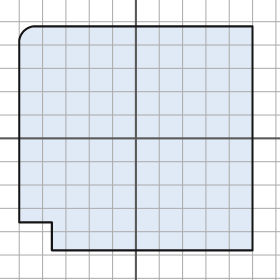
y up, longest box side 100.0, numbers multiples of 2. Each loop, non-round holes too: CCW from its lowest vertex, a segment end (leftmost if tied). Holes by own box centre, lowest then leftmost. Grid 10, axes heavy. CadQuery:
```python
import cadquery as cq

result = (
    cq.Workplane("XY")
    .moveTo(-36.0, -48.0)
    .lineTo(50.0, -48.0)
    .lineTo(50.0, 48.0)
    .lineTo(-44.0, 48.0)
    .threePointArc((-48.0, 46.0), (-50.0, 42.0))
    .lineTo(-50.0, -36.0)
    .lineTo(-36.0, -36.0)
    .close()
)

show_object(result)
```